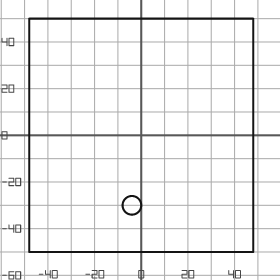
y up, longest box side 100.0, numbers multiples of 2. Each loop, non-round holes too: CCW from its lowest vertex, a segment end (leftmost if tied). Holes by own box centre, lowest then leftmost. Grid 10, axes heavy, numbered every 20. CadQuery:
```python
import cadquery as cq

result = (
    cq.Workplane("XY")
    .moveTo(-48.0, -50.0)
    .lineTo(48.0, -50.0)
    .lineTo(48.0, 50.0)
    .lineTo(-48.0, 50.0)
    .close()
    .moveTo(-4.0, -30.0)
    .circle(4.0)
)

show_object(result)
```